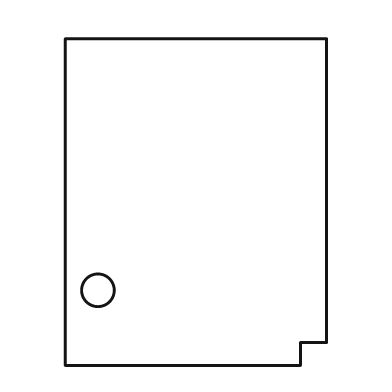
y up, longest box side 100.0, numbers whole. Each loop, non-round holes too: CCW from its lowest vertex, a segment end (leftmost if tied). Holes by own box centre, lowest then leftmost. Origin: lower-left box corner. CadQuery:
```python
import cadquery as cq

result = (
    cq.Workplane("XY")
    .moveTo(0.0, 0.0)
    .lineTo(72.0, 0.0)
    .lineTo(72.0, 7.0)
    .lineTo(80.0, 7.0)
    .lineTo(80.0, 100.0)
    .lineTo(0.0, 100.0)
    .close()
    .moveTo(10.0, 23.0)
    .circle(5.0)
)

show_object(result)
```